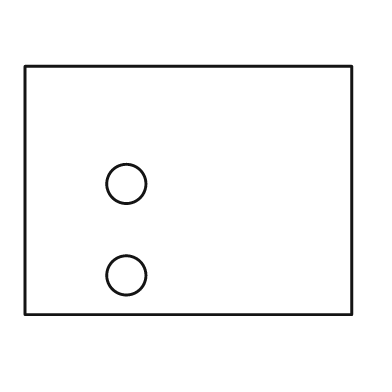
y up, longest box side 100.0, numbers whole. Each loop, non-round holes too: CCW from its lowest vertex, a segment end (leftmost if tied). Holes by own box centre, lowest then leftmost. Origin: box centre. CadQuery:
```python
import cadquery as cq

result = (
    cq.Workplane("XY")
    .moveTo(-50.0, -38.0)
    .lineTo(50.0, -38.0)
    .lineTo(50.0, 38.0)
    .lineTo(-50.0, 38.0)
    .close()
    .moveTo(-19.0, -26.0)
    .circle(6.0)
    .moveTo(-19.0, 2.0)
    .circle(6.0)
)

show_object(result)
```